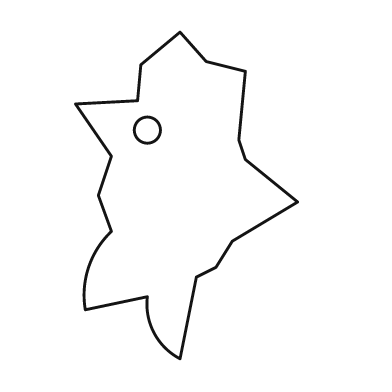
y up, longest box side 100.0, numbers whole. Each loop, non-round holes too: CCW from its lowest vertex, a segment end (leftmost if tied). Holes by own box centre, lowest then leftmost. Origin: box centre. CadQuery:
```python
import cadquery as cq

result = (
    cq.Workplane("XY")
    .moveTo(-2.0, -50.0)
    .lineTo(3.0, -25.0)
    .lineTo(9.0, -22.0)
    .lineTo(14.0, -14.0)
    .lineTo(34.0, -2.0)
    .lineTo(18.0, 11.0)
    .lineTo(16.0, 17.0)
    .lineTo(18.0, 38.0)
    .lineTo(6.0, 41.0)
    .lineTo(-2.0, 50.0)
    .lineTo(-14.0, 40.0)
    .lineTo(-15.0, 29.0)
    .lineTo(-34.0, 28.0)
    .lineTo(-23.0, 12.0)
    .lineTo(-27.0, 0.0)
    .lineTo(-23.0, -11.0)
    .threePointArc((-30.0, -22.0), (-31.0, -35.0))
    .lineTo(-12.0, -31.0)
    .threePointArc((-10.0, -42.0), (-2.0, -50.0))
    .close()
    .moveTo(-12.0, 20.0)
    .circle(4.0)
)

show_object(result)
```